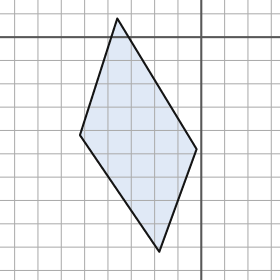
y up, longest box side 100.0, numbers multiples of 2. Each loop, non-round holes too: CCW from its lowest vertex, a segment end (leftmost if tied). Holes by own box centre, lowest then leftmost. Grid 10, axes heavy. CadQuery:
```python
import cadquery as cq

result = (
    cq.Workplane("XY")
    .moveTo(-18.0, -92.0)
    .lineTo(-2.0, -48.0)
    .lineTo(-36.0, 8.0)
    .lineTo(-52.0, -42.0)
    .close()
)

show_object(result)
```